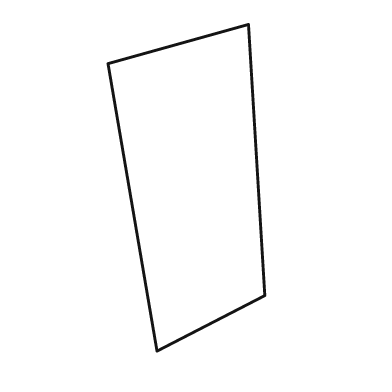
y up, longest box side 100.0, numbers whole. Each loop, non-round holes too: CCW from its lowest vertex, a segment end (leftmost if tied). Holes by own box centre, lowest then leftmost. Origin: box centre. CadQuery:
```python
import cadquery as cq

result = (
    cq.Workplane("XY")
    .moveTo(-9.0, -50.0)
    .lineTo(24.0, -33.0)
    .lineTo(19.0, 50.0)
    .lineTo(-24.0, 38.0)
    .close()
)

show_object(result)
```